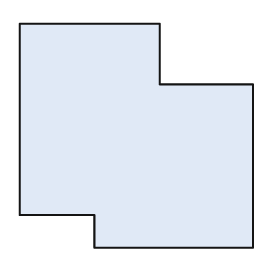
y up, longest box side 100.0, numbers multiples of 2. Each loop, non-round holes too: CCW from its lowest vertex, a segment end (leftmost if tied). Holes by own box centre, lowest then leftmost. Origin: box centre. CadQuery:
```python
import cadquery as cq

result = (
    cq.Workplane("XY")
    .moveTo(-18.0, -48.0)
    .lineTo(50.0, -48.0)
    .lineTo(50.0, 22.0)
    .lineTo(10.0, 22.0)
    .lineTo(10.0, 48.0)
    .lineTo(-50.0, 48.0)
    .lineTo(-50.0, -34.0)
    .lineTo(-18.0, -34.0)
    .close()
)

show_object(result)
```